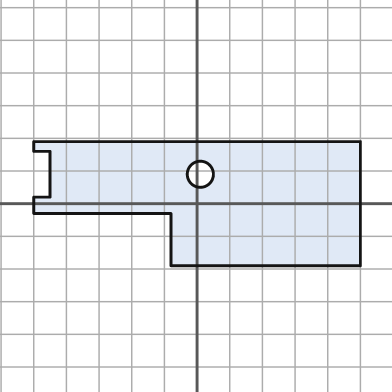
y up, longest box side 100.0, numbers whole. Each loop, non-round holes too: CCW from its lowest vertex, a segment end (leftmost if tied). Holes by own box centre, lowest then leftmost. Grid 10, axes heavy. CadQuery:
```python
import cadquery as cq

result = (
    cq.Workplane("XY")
    .moveTo(-8.0, -19.0)
    .lineTo(50.0, -19.0)
    .lineTo(50.0, 19.0)
    .lineTo(-50.0, 19.0)
    .lineTo(-50.0, 16.0)
    .lineTo(-45.0, 16.0)
    .lineTo(-45.0, 2.0)
    .lineTo(-50.0, 2.0)
    .lineTo(-50.0, -3.0)
    .lineTo(-8.0, -3.0)
    .close()
    .moveTo(1.0, 9.0)
    .circle(4.0)
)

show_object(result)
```